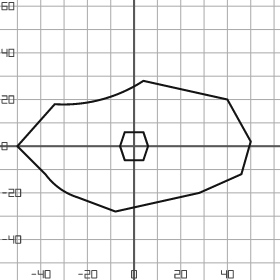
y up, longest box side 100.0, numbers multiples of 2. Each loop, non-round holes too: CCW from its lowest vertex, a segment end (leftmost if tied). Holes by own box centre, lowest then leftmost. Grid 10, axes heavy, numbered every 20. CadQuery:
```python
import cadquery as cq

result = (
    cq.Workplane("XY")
    .moveTo(-8.0, -28.0)
    .lineTo(28.0, -20.0)
    .lineTo(46.0, -12.0)
    .lineTo(50.0, 2.0)
    .lineTo(40.0, 20.0)
    .lineTo(4.0, 28.0)
    .threePointArc((-14.0, 20.0), (-34.0, 18.0))
    .lineTo(-50.0, 0.0)
    .lineTo(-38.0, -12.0)
    .threePointArc((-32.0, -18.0), (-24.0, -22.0))
    .close()
    .moveTo(-4.0, -6.0)
    .lineTo(4.0, -6.0)
    .lineTo(6.0, 0.0)
    .lineTo(4.0, 6.0)
    .lineTo(-4.0, 6.0)
    .lineTo(-6.0, 0.0)
    .close()
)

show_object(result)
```